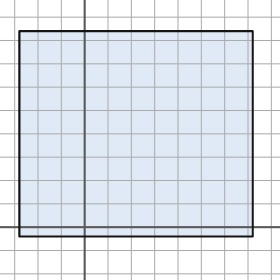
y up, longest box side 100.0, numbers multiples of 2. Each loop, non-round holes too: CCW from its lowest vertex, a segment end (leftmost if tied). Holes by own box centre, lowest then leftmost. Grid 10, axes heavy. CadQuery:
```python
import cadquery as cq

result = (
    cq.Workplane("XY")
    .moveTo(-28.0, -4.0)
    .lineTo(72.0, -4.0)
    .lineTo(72.0, 84.0)
    .lineTo(-28.0, 84.0)
    .close()
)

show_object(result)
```